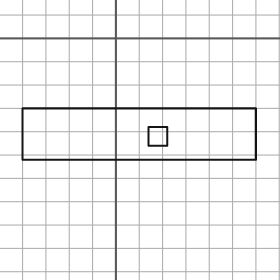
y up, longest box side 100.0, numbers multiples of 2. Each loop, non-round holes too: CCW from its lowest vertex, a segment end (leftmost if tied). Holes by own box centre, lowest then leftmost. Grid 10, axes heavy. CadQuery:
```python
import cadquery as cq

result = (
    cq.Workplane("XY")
    .moveTo(-40.0, -52.0)
    .lineTo(60.0, -52.0)
    .lineTo(60.0, -30.0)
    .lineTo(-40.0, -30.0)
    .close()
    .moveTo(14.0, -46.0)
    .lineTo(22.0, -46.0)
    .lineTo(22.0, -38.0)
    .lineTo(14.0, -38.0)
    .close()
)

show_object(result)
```